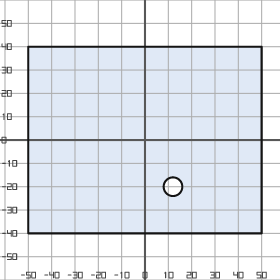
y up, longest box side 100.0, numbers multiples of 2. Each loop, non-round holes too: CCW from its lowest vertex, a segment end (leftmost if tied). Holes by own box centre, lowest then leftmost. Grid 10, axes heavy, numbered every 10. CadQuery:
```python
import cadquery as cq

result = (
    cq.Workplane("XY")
    .moveTo(-50.0, -40.0)
    .lineTo(50.0, -40.0)
    .lineTo(50.0, 40.0)
    .lineTo(-50.0, 40.0)
    .close()
    .moveTo(12.0, -20.0)
    .circle(4.0)
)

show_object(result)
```